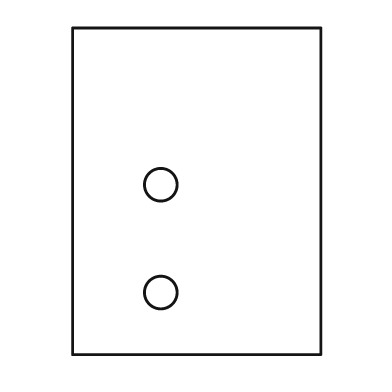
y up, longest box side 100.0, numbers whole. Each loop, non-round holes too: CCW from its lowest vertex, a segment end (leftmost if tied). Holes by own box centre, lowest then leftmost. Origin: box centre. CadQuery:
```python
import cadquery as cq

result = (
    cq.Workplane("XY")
    .moveTo(-38.0, -50.0)
    .lineTo(38.0, -50.0)
    .lineTo(38.0, 50.0)
    .lineTo(-38.0, 50.0)
    .close()
    .moveTo(-11.0, -31.0)
    .circle(5.0)
    .moveTo(-11.0, 2.0)
    .circle(5.0)
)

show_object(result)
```